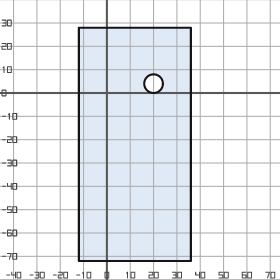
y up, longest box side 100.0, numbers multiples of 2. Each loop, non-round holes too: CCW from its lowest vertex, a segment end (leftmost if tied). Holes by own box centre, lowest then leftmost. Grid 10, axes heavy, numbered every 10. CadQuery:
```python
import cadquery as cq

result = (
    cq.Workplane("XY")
    .moveTo(-12.0, -72.0)
    .lineTo(36.0, -72.0)
    .lineTo(36.0, 28.0)
    .lineTo(-12.0, 28.0)
    .close()
    .moveTo(20.0, 4.0)
    .circle(4.0)
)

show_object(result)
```